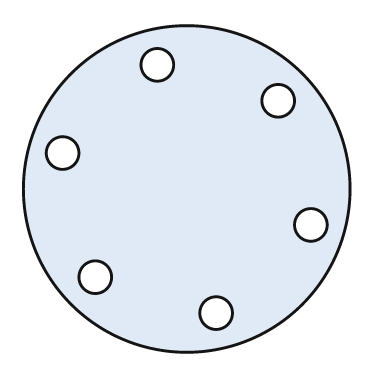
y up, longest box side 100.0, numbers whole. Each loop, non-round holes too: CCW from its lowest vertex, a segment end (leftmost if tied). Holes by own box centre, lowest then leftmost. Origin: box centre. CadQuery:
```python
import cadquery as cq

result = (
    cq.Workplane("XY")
    .moveTo(0.0, 0.0)
    .circle(50.0)
    .moveTo(9.0, -38.0)
    .circle(5.0)
    .moveTo(-28.0, -27.0)
    .circle(5.0)
    .moveTo(38.0, -11.0)
    .circle(5.0)
    .moveTo(-38.0, 11.0)
    .circle(5.0)
    .moveTo(28.0, 27.0)
    .circle(5.0)
    .moveTo(-9.0, 38.0)
    .circle(5.0)
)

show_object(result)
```